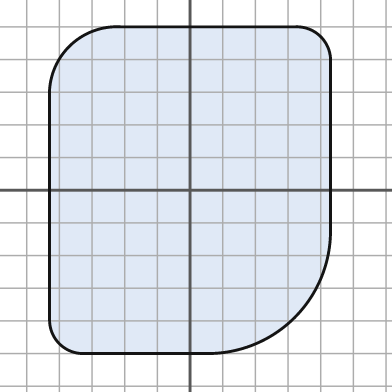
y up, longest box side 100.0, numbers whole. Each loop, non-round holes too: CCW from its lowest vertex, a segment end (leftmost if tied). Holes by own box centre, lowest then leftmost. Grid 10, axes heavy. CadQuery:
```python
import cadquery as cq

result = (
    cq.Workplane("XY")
    .moveTo(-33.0, -50.0)
    .lineTo(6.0, -50.0)
    .threePointArc((32.0, -39.0), (43.0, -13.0))
    .lineTo(43.0, 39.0)
    .threePointArc((40.0, 47.0), (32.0, 50.0))
    .lineTo(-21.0, 50.0)
    .threePointArc((-37.0, 44.0), (-43.0, 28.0))
    .lineTo(-43.0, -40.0)
    .threePointArc((-40.0, -47.0), (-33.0, -50.0))
    .close()
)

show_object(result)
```